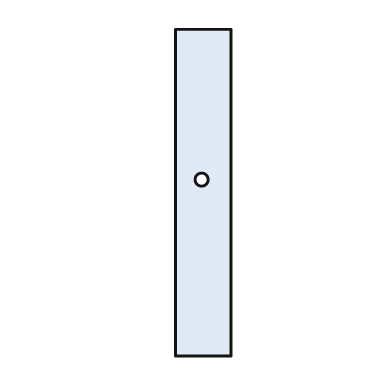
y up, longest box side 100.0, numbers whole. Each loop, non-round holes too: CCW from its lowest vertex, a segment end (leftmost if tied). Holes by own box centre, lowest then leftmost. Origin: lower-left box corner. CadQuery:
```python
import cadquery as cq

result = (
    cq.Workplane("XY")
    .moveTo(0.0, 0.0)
    .lineTo(17.0, 0.0)
    .lineTo(17.0, 100.0)
    .lineTo(0.0, 100.0)
    .close()
    .moveTo(8.0, 54.0)
    .circle(2.0)
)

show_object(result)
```